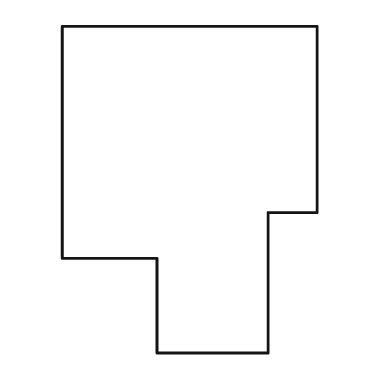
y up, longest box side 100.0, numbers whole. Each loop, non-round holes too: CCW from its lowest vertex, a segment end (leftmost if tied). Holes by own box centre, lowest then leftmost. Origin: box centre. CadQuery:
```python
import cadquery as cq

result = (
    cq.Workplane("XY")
    .moveTo(-10.0, -50.0)
    .lineTo(24.0, -50.0)
    .lineTo(24.0, -7.0)
    .lineTo(39.0, -7.0)
    .lineTo(39.0, 50.0)
    .lineTo(-39.0, 50.0)
    .lineTo(-39.0, -21.0)
    .lineTo(-10.0, -21.0)
    .close()
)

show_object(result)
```